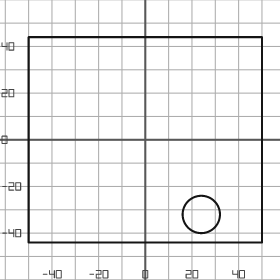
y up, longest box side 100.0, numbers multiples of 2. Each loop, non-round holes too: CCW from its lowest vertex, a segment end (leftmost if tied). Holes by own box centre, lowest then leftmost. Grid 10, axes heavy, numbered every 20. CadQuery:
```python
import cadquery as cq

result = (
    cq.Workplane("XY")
    .moveTo(-50.0, -44.0)
    .lineTo(50.0, -44.0)
    .lineTo(50.0, 44.0)
    .lineTo(-50.0, 44.0)
    .close()
    .moveTo(24.0, -32.0)
    .circle(8.0)
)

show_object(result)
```